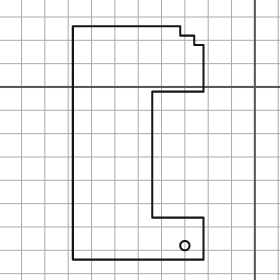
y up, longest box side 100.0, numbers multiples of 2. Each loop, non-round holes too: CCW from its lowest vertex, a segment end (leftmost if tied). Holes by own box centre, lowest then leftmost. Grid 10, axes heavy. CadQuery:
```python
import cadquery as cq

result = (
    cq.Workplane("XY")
    .moveTo(-78.0, -74.0)
    .lineTo(-22.0, -74.0)
    .lineTo(-22.0, -56.0)
    .lineTo(-44.0, -56.0)
    .lineTo(-44.0, -2.0)
    .lineTo(-22.0, -2.0)
    .lineTo(-22.0, 18.0)
    .lineTo(-26.0, 18.0)
    .lineTo(-26.0, 22.0)
    .lineTo(-32.0, 22.0)
    .lineTo(-32.0, 26.0)
    .lineTo(-78.0, 26.0)
    .close()
    .moveTo(-30.0, -68.0)
    .circle(2.0)
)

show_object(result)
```